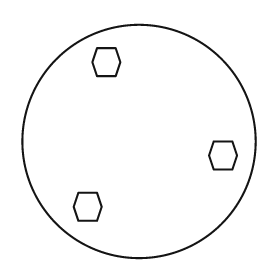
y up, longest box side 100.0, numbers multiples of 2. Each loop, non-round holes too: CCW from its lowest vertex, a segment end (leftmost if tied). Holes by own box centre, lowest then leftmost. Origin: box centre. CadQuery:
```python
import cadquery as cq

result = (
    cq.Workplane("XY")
    .moveTo(0.0, 0.0)
    .circle(50.0)
    .moveTo(-26.0, -34.0)
    .lineTo(-18.0, -34.0)
    .lineTo(-16.0, -28.0)
    .lineTo(-18.0, -22.0)
    .lineTo(-26.0, -22.0)
    .lineTo(-28.0, -28.0)
    .close()
    .moveTo(32.0, -12.0)
    .lineTo(40.0, -12.0)
    .lineTo(42.0, -6.0)
    .lineTo(40.0, 0.0)
    .lineTo(32.0, 0.0)
    .lineTo(30.0, -6.0)
    .close()
    .moveTo(-18.0, 28.0)
    .lineTo(-10.0, 28.0)
    .lineTo(-8.0, 34.0)
    .lineTo(-10.0, 40.0)
    .lineTo(-18.0, 40.0)
    .lineTo(-20.0, 34.0)
    .close()
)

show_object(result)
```